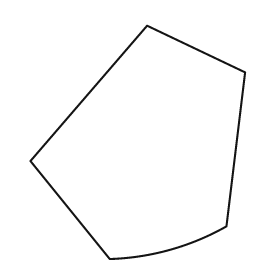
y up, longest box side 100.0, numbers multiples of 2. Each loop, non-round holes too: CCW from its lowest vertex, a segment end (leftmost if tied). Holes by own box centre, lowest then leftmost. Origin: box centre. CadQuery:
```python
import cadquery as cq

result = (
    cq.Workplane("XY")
    .moveTo(-12.0, -50.0)
    .threePointArc((14.0, -46.0), (38.0, -36.0))
    .lineTo(46.0, 30.0)
    .lineTo(4.0, 50.0)
    .lineTo(-46.0, -8.0)
    .close()
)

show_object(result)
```